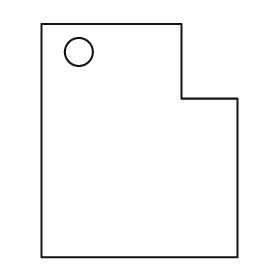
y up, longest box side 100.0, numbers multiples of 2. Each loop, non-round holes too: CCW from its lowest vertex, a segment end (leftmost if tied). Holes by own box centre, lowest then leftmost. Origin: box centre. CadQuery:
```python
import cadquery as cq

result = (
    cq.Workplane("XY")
    .moveTo(-42.0, -50.0)
    .lineTo(42.0, -50.0)
    .lineTo(42.0, 18.0)
    .lineTo(18.0, 18.0)
    .lineTo(18.0, 50.0)
    .lineTo(-42.0, 50.0)
    .close()
    .moveTo(-26.0, 38.0)
    .circle(6.0)
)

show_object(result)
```